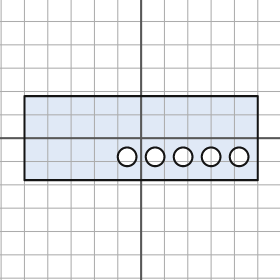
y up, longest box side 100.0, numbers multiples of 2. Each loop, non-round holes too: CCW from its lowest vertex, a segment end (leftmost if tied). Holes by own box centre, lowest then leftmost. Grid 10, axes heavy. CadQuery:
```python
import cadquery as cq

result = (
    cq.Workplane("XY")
    .moveTo(-50.0, -18.0)
    .lineTo(50.0, -18.0)
    .lineTo(50.0, 18.0)
    .lineTo(-50.0, 18.0)
    .close()
    .moveTo(-6.0, -8.0)
    .circle(4.0)
    .moveTo(6.0, -8.0)
    .circle(4.0)
    .moveTo(18.0, -8.0)
    .circle(4.0)
    .moveTo(30.0, -8.0)
    .circle(4.0)
    .moveTo(42.0, -8.0)
    .circle(4.0)
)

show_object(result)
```